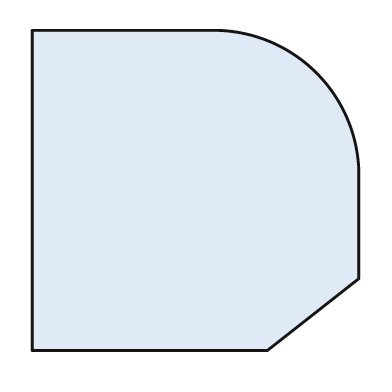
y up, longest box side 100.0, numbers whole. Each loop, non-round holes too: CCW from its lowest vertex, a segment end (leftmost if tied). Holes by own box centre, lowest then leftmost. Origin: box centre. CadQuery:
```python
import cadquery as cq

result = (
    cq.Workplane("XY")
    .moveTo(-50.0, -49.0)
    .lineTo(22.0, -49.0)
    .lineTo(50.0, -27.0)
    .lineTo(50.0, 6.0)
    .threePointArc((37.0, 36.0), (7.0, 49.0))
    .lineTo(-50.0, 49.0)
    .close()
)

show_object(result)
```